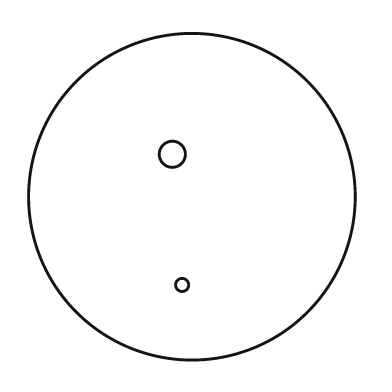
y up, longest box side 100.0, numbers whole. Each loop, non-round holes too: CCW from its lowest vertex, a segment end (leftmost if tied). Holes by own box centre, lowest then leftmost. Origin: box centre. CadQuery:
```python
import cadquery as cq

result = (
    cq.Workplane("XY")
    .moveTo(0.0, 0.0)
    .circle(50.0)
    .moveTo(-3.0, -27.0)
    .circle(2.0)
    .moveTo(-6.0, 13.0)
    .circle(4.0)
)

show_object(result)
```